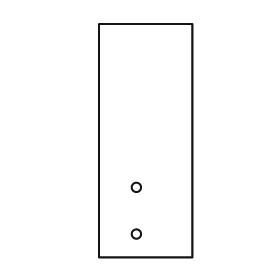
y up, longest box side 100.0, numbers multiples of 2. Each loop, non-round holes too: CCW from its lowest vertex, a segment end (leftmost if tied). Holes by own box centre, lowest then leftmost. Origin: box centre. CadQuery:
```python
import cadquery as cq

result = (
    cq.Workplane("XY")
    .moveTo(-20.0, -50.0)
    .lineTo(20.0, -50.0)
    .lineTo(20.0, 50.0)
    .lineTo(-20.0, 50.0)
    .close()
    .moveTo(-4.0, -40.0)
    .circle(2.0)
    .moveTo(-4.0, -20.0)
    .circle(2.0)
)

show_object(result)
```